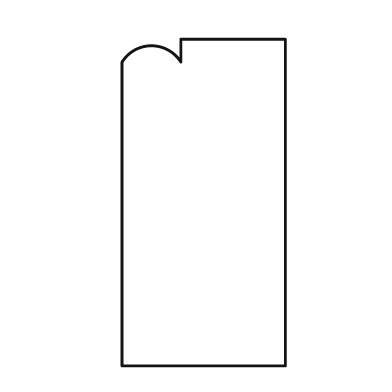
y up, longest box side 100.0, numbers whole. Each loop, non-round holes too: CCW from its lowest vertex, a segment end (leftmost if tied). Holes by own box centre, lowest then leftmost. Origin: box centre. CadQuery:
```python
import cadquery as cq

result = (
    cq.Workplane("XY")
    .moveTo(-25.0, -50.0)
    .lineTo(25.0, -50.0)
    .lineTo(25.0, 50.0)
    .lineTo(-7.0, 50.0)
    .lineTo(-7.0, 43.0)
    .threePointArc((-16.0, 48.0), (-25.0, 43.0))
    .close()
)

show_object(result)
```